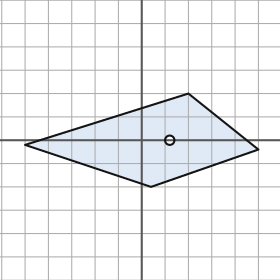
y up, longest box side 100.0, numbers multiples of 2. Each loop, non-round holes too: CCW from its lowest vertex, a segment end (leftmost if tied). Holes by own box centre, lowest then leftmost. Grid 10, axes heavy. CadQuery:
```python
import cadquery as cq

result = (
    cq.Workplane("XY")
    .moveTo(4.0, -20.0)
    .lineTo(50.0, -4.0)
    .lineTo(20.0, 20.0)
    .lineTo(-50.0, -2.0)
    .close()
    .moveTo(12.0, 0.0)
    .circle(2.0)
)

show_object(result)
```